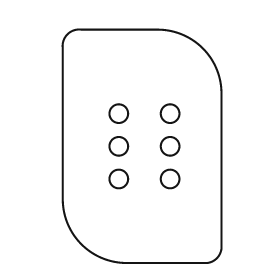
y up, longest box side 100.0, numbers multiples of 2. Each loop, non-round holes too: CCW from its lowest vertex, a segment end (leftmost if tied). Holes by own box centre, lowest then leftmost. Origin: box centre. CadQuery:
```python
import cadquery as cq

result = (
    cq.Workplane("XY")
    .moveTo(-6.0, -50.0)
    .lineTo(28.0, -50.0)
    .threePointArc((32.0, -48.0), (34.0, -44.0))
    .lineTo(34.0, 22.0)
    .threePointArc((26.0, 42.0), (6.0, 50.0))
    .lineTo(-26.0, 50.0)
    .threePointArc((-32.0, 48.0), (-34.0, 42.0))
    .lineTo(-34.0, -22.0)
    .threePointArc((-26.0, -42.0), (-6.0, -50.0))
    .close()
    .moveTo(-10.0, -14.0)
    .circle(4.0)
    .moveTo(12.0, -14.0)
    .circle(4.0)
    .moveTo(-10.0, 0.0)
    .circle(4.0)
    .moveTo(12.0, 0.0)
    .circle(4.0)
    .moveTo(-10.0, 14.0)
    .circle(4.0)
    .moveTo(12.0, 14.0)
    .circle(4.0)
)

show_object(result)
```